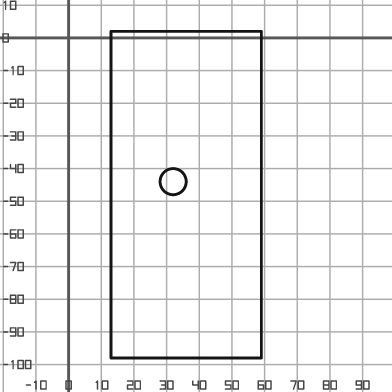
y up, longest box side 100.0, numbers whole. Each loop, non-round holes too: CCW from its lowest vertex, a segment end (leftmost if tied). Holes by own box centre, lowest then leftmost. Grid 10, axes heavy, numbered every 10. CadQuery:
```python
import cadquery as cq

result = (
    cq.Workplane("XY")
    .moveTo(13.0, -98.0)
    .lineTo(59.0, -98.0)
    .lineTo(59.0, 2.0)
    .lineTo(13.0, 2.0)
    .close()
    .moveTo(32.0, -44.0)
    .circle(4.0)
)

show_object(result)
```